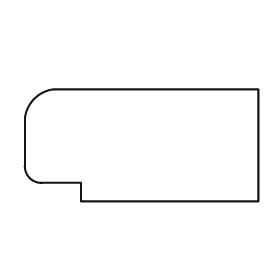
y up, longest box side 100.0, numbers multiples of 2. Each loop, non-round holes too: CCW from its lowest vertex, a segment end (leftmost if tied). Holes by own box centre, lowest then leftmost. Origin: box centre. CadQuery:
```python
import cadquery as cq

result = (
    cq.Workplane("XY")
    .moveTo(-26.0, -24.0)
    .lineTo(50.0, -24.0)
    .lineTo(50.0, 24.0)
    .lineTo(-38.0, 24.0)
    .threePointArc((-46.0, 20.0), (-50.0, 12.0))
    .lineTo(-50.0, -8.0)
    .threePointArc((-48.0, -14.0), (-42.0, -16.0))
    .lineTo(-26.0, -16.0)
    .close()
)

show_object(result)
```